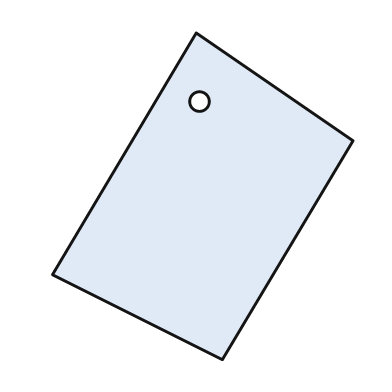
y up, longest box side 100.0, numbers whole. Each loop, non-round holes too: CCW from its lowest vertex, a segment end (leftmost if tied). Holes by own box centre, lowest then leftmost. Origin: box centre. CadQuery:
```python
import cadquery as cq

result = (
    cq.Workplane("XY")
    .moveTo(6.0, -50.0)
    .lineTo(46.0, 17.0)
    .lineTo(-2.0, 50.0)
    .lineTo(-46.0, -24.0)
    .close()
    .moveTo(-1.0, 29.0)
    .circle(3.0)
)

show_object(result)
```